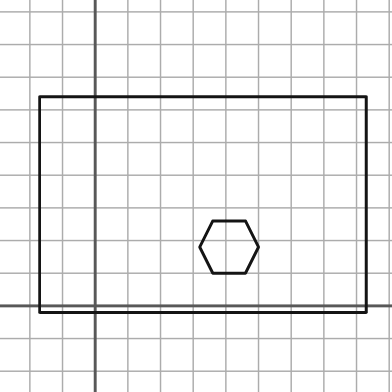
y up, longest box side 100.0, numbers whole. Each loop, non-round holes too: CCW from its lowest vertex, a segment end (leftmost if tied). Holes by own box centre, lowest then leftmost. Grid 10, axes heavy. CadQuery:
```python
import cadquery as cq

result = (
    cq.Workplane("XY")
    .moveTo(-17.0, -2.0)
    .lineTo(83.0, -2.0)
    .lineTo(83.0, 64.0)
    .lineTo(-17.0, 64.0)
    .close()
    .moveTo(36.0, 10.0)
    .lineTo(46.0, 10.0)
    .lineTo(50.0, 18.0)
    .lineTo(46.0, 26.0)
    .lineTo(36.0, 26.0)
    .lineTo(32.0, 18.0)
    .close()
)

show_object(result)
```